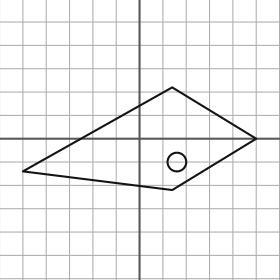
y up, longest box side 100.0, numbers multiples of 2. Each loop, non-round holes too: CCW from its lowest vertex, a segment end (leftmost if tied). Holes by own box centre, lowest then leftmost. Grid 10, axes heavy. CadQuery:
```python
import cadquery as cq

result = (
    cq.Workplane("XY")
    .moveTo(14.0, -22.0)
    .lineTo(50.0, 0.0)
    .lineTo(14.0, 22.0)
    .lineTo(-50.0, -14.0)
    .close()
    .moveTo(16.0, -10.0)
    .circle(4.0)
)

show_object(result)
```